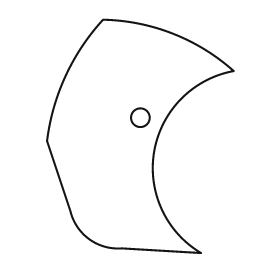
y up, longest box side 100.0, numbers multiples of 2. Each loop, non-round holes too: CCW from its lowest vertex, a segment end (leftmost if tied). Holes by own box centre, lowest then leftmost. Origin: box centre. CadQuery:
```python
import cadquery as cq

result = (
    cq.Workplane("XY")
    .moveTo(26.0, -50.0)
    .threePointArc((6.0, -6.0), (40.0, 28.0))
    .threePointArc((14.0, 44.0), (-16.0, 50.0))
    .threePointArc((-32.0, 26.0), (-40.0, -2.0))
    .lineTo(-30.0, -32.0)
    .threePointArc((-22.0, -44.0), (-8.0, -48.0))
    .close()
    .moveTo(0.0, 8.0)
    .circle(4.0)
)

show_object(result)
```